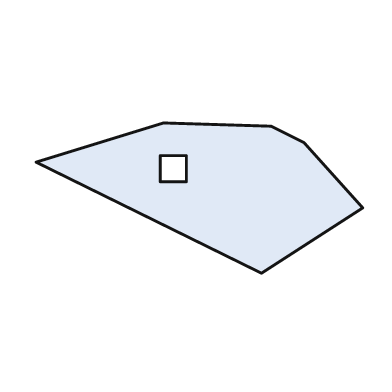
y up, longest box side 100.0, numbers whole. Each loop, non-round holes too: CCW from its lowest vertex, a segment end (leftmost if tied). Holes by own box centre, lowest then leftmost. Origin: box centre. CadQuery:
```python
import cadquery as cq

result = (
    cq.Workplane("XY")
    .moveTo(19.0, -23.0)
    .lineTo(50.0, -3.0)
    .lineTo(32.0, 17.0)
    .lineTo(22.0, 22.0)
    .lineTo(-11.0, 23.0)
    .lineTo(-50.0, 11.0)
    .close()
    .moveTo(-12.0, 5.0)
    .lineTo(-4.0, 5.0)
    .lineTo(-4.0, 13.0)
    .lineTo(-12.0, 13.0)
    .close()
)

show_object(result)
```